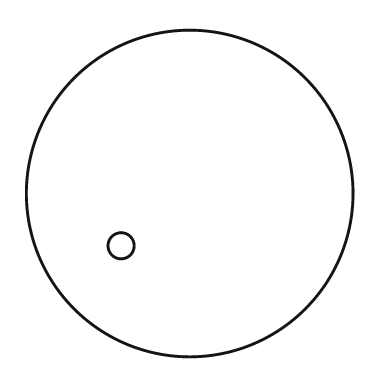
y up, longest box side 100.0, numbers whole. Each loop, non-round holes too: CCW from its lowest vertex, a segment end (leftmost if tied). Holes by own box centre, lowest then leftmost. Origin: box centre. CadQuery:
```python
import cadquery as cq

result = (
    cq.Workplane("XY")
    .moveTo(0.0, 0.0)
    .circle(50.0)
    .moveTo(-21.0, -16.0)
    .circle(4.0)
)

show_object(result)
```